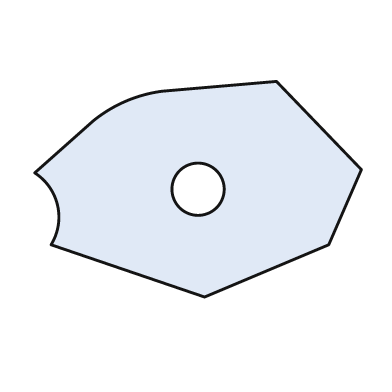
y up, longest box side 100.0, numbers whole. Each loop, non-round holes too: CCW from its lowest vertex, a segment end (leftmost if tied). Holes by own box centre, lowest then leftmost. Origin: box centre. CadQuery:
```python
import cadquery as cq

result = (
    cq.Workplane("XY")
    .moveTo(2.0, -33.0)
    .lineTo(40.0, -17.0)
    .lineTo(50.0, 6.0)
    .lineTo(24.0, 33.0)
    .lineTo(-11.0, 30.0)
    .threePointArc((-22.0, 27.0), (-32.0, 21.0))
    .lineTo(-50.0, 5.0)
    .threePointArc((-43.0, -5.0), (-45.0, -17.0))
    .close()
    .moveTo(0.0, 0.0)
    .circle(8.0)
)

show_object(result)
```